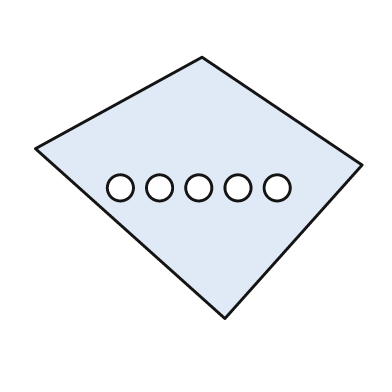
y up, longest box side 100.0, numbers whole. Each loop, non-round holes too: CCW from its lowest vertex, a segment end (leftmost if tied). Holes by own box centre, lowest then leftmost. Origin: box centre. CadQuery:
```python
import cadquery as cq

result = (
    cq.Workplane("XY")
    .moveTo(8.0, -40.0)
    .lineTo(50.0, 7.0)
    .lineTo(1.0, 40.0)
    .lineTo(-50.0, 12.0)
    .close()
    .moveTo(-24.0, 0.0)
    .circle(4.0)
    .moveTo(-12.0, 0.0)
    .circle(4.0)
    .moveTo(0.0, 0.0)
    .circle(4.0)
    .moveTo(12.0, 0.0)
    .circle(4.0)
    .moveTo(24.0, 0.0)
    .circle(4.0)
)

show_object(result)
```